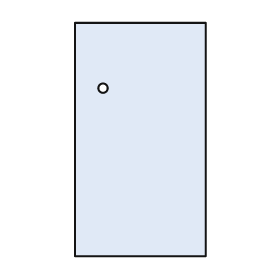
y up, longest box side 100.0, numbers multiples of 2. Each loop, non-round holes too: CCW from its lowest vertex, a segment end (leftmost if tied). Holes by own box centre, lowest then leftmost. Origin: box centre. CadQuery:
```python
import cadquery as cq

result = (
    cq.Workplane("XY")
    .moveTo(-28.0, -50.0)
    .lineTo(28.0, -50.0)
    .lineTo(28.0, 50.0)
    .lineTo(-28.0, 50.0)
    .close()
    .moveTo(-16.0, 22.0)
    .circle(2.0)
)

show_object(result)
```